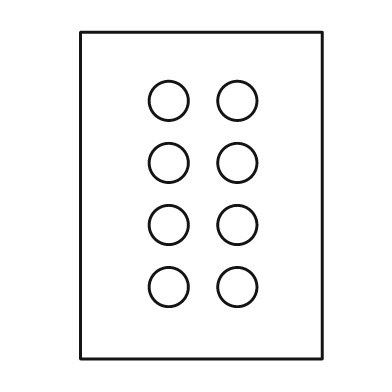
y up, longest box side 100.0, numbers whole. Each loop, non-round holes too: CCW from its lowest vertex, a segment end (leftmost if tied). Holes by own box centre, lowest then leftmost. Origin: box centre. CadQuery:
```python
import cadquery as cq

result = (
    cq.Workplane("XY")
    .moveTo(-37.0, -50.0)
    .lineTo(37.0, -50.0)
    .lineTo(37.0, 50.0)
    .lineTo(-37.0, 50.0)
    .close()
    .moveTo(-10.0, -28.0)
    .circle(6.0)
    .moveTo(11.0, -28.0)
    .circle(6.0)
    .moveTo(-10.0, -9.0)
    .circle(6.0)
    .moveTo(11.0, -9.0)
    .circle(6.0)
    .moveTo(-10.0, 10.0)
    .circle(6.0)
    .moveTo(11.0, 10.0)
    .circle(6.0)
    .moveTo(-10.0, 29.0)
    .circle(6.0)
    .moveTo(11.0, 29.0)
    .circle(6.0)
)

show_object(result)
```